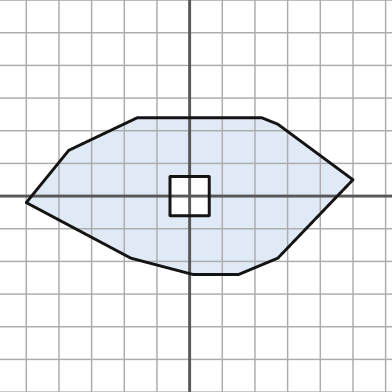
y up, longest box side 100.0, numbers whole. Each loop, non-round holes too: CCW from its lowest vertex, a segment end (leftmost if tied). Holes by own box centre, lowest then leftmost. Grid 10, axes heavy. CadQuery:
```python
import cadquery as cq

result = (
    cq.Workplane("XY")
    .moveTo(1.0, -24.0)
    .lineTo(15.0, -24.0)
    .lineTo(27.0, -19.0)
    .lineTo(50.0, 5.0)
    .lineTo(27.0, 22.0)
    .lineTo(22.0, 24.0)
    .lineTo(-16.0, 24.0)
    .lineTo(-37.0, 14.0)
    .lineTo(-50.0, -2.0)
    .lineTo(-18.0, -19.0)
    .close()
    .moveTo(-6.0, -6.0)
    .lineTo(6.0, -6.0)
    .lineTo(6.0, 6.0)
    .lineTo(-6.0, 6.0)
    .close()
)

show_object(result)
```